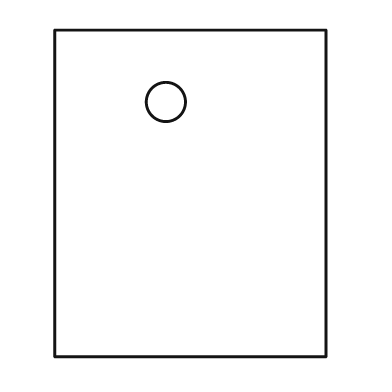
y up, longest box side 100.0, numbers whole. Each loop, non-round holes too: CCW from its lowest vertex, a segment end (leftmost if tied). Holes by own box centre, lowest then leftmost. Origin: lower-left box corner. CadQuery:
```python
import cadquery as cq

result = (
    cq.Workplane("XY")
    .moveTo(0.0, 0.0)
    .lineTo(83.0, 0.0)
    .lineTo(83.0, 100.0)
    .lineTo(0.0, 100.0)
    .close()
    .moveTo(34.0, 78.0)
    .circle(6.0)
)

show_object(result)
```